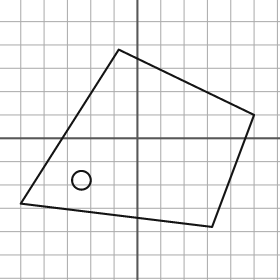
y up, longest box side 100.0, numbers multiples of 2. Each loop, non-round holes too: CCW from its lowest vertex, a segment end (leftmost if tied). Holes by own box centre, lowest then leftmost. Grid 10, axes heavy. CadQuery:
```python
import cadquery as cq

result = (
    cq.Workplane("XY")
    .moveTo(32.0, -38.0)
    .lineTo(50.0, 10.0)
    .lineTo(-8.0, 38.0)
    .lineTo(-50.0, -28.0)
    .close()
    .moveTo(-24.0, -18.0)
    .circle(4.0)
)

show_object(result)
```